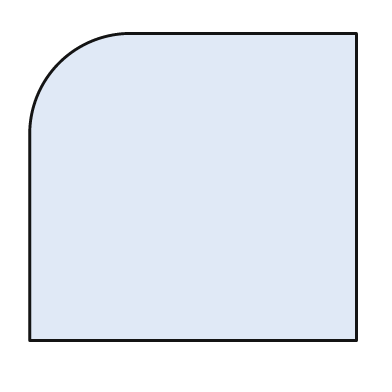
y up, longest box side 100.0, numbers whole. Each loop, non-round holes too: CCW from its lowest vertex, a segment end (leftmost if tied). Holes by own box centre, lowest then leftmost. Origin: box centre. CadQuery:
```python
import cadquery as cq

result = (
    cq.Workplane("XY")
    .moveTo(-50.0, -47.0)
    .lineTo(50.0, -47.0)
    .lineTo(50.0, 47.0)
    .lineTo(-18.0, 47.0)
    .threePointArc((-41.0, 38.0), (-50.0, 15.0))
    .close()
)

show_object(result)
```